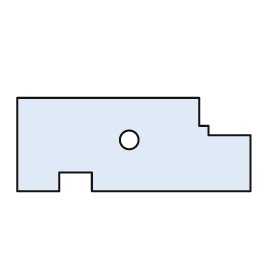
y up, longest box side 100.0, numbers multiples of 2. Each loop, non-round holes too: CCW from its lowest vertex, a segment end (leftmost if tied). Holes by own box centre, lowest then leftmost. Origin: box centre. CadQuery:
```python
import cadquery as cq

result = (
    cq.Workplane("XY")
    .moveTo(-50.0, -20.0)
    .lineTo(-32.0, -20.0)
    .lineTo(-32.0, -12.0)
    .lineTo(-18.0, -12.0)
    .lineTo(-18.0, -20.0)
    .lineTo(50.0, -20.0)
    .lineTo(50.0, 4.0)
    .lineTo(32.0, 4.0)
    .lineTo(32.0, 8.0)
    .lineTo(28.0, 8.0)
    .lineTo(28.0, 20.0)
    .lineTo(-50.0, 20.0)
    .close()
    .moveTo(-2.0, 2.0)
    .circle(4.0)
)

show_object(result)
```